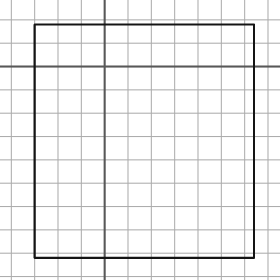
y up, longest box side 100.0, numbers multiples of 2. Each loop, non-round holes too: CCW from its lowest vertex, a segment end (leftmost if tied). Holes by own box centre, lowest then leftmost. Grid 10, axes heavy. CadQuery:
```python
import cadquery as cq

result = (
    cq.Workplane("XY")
    .moveTo(-30.0, -82.0)
    .lineTo(64.0, -82.0)
    .lineTo(64.0, 18.0)
    .lineTo(-30.0, 18.0)
    .close()
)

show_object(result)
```